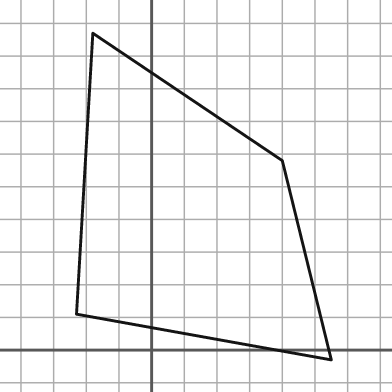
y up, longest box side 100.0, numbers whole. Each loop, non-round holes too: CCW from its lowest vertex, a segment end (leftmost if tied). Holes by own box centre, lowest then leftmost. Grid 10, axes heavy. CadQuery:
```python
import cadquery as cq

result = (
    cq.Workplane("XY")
    .moveTo(55.0, -3.0)
    .lineTo(40.0, 58.0)
    .lineTo(-18.0, 97.0)
    .lineTo(-23.0, 11.0)
    .close()
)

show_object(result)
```